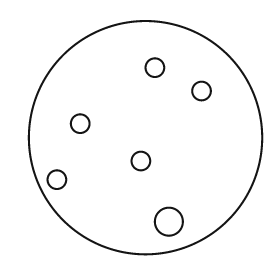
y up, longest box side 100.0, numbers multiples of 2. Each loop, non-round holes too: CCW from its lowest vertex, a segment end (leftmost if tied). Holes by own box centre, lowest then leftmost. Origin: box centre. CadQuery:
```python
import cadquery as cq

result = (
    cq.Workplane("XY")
    .moveTo(0.0, 0.0)
    .circle(50.0)
    .moveTo(10.0, -36.0)
    .circle(6.0)
    .moveTo(-38.0, -18.0)
    .circle(4.0)
    .moveTo(-2.0, -10.0)
    .circle(4.0)
    .moveTo(-28.0, 6.0)
    .circle(4.0)
    .moveTo(24.0, 20.0)
    .circle(4.0)
    .moveTo(4.0, 30.0)
    .circle(4.0)
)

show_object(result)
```